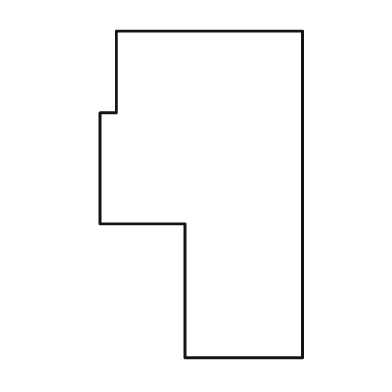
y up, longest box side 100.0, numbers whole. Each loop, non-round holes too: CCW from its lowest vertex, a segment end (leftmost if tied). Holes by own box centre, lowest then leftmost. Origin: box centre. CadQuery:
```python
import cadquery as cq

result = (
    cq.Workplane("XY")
    .moveTo(-5.0, -50.0)
    .lineTo(31.0, -50.0)
    .lineTo(31.0, 50.0)
    .lineTo(-26.0, 50.0)
    .lineTo(-26.0, 25.0)
    .lineTo(-31.0, 25.0)
    .lineTo(-31.0, -9.0)
    .lineTo(-5.0, -9.0)
    .close()
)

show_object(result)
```